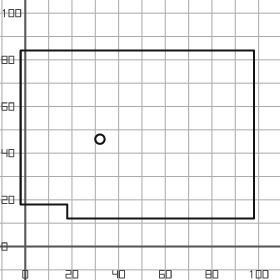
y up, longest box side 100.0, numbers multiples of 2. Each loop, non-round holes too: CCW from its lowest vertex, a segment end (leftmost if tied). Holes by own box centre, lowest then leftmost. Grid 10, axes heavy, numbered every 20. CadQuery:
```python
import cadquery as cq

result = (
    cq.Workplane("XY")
    .moveTo(18.0, 12.0)
    .lineTo(98.0, 12.0)
    .lineTo(98.0, 84.0)
    .lineTo(-2.0, 84.0)
    .lineTo(-2.0, 18.0)
    .lineTo(18.0, 18.0)
    .close()
    .moveTo(32.0, 46.0)
    .circle(2.0)
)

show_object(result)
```